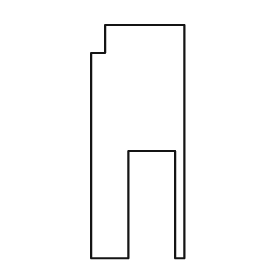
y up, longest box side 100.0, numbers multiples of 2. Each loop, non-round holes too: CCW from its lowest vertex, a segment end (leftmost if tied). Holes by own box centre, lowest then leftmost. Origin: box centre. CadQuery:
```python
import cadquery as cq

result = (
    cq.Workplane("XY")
    .moveTo(-20.0, -50.0)
    .lineTo(-4.0, -50.0)
    .lineTo(-4.0, -4.0)
    .lineTo(16.0, -4.0)
    .lineTo(16.0, -50.0)
    .lineTo(20.0, -50.0)
    .lineTo(20.0, 50.0)
    .lineTo(-14.0, 50.0)
    .lineTo(-14.0, 38.0)
    .lineTo(-20.0, 38.0)
    .close()
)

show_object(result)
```